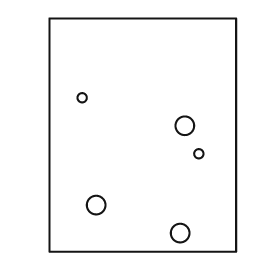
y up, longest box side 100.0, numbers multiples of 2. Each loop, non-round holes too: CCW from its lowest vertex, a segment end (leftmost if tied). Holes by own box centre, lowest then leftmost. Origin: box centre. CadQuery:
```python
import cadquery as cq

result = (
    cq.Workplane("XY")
    .moveTo(-40.0, -50.0)
    .lineTo(40.0, -50.0)
    .lineTo(40.0, 50.0)
    .lineTo(-40.0, 50.0)
    .close()
    .moveTo(16.0, -42.0)
    .circle(4.0)
    .moveTo(-20.0, -30.0)
    .circle(4.0)
    .moveTo(24.0, -8.0)
    .circle(2.0)
    .moveTo(18.0, 4.0)
    .circle(4.0)
    .moveTo(-26.0, 16.0)
    .circle(2.0)
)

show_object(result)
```